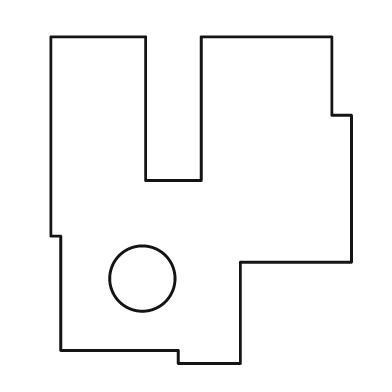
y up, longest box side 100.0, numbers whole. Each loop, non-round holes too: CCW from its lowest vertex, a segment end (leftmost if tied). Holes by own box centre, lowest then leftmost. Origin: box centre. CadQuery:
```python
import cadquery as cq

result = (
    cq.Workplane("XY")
    .moveTo(-7.0, -50.0)
    .lineTo(12.0, -50.0)
    .lineTo(12.0, -19.0)
    .lineTo(46.0, -19.0)
    .lineTo(46.0, 26.0)
    .lineTo(40.0, 26.0)
    .lineTo(40.0, 50.0)
    .lineTo(0.0, 50.0)
    .lineTo(0.0, 6.0)
    .lineTo(-17.0, 6.0)
    .lineTo(-17.0, 50.0)
    .lineTo(-46.0, 50.0)
    .lineTo(-46.0, -11.0)
    .lineTo(-43.0, -11.0)
    .lineTo(-43.0, -46.0)
    .lineTo(-7.0, -46.0)
    .close()
    .moveTo(-18.0, -24.0)
    .circle(10.0)
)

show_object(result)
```